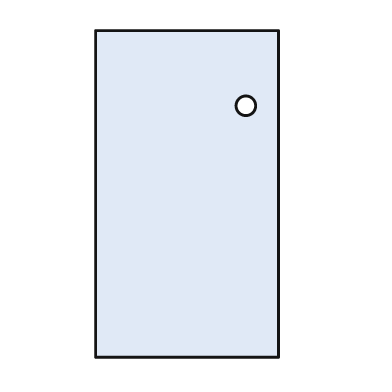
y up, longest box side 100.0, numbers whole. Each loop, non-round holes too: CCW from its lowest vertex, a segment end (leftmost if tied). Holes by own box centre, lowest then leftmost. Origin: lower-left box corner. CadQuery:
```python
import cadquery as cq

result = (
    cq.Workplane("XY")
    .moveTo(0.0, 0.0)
    .lineTo(56.0, 0.0)
    .lineTo(56.0, 100.0)
    .lineTo(0.0, 100.0)
    .close()
    .moveTo(46.0, 77.0)
    .circle(3.0)
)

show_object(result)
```